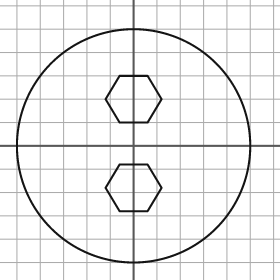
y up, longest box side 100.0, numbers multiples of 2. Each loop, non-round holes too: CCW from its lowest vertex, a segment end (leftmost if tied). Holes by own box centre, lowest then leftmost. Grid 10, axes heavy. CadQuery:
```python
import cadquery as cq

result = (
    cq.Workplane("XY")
    .moveTo(0.0, 0.0)
    .circle(50.0)
    .moveTo(-6.0, -28.0)
    .lineTo(6.0, -28.0)
    .lineTo(12.0, -18.0)
    .lineTo(6.0, -8.0)
    .lineTo(-6.0, -8.0)
    .lineTo(-12.0, -18.0)
    .close()
    .moveTo(-6.0, 10.0)
    .lineTo(6.0, 10.0)
    .lineTo(12.0, 20.0)
    .lineTo(6.0, 30.0)
    .lineTo(-6.0, 30.0)
    .lineTo(-12.0, 20.0)
    .close()
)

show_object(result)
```